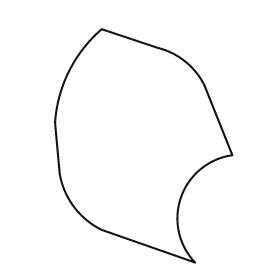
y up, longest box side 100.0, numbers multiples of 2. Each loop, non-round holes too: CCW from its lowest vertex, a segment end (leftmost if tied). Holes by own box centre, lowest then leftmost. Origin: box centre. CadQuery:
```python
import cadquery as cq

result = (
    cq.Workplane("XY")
    .moveTo(22.0, -50.0)
    .threePointArc((16.0, -22.0), (38.0, -4.0))
    .lineTo(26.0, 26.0)
    .threePointArc((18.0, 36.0), (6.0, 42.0))
    .lineTo(-18.0, 50.0)
    .threePointArc((-32.0, 32.0), (-38.0, 10.0))
    .lineTo(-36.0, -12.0)
    .threePointArc((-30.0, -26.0), (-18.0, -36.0))
    .close()
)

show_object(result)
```